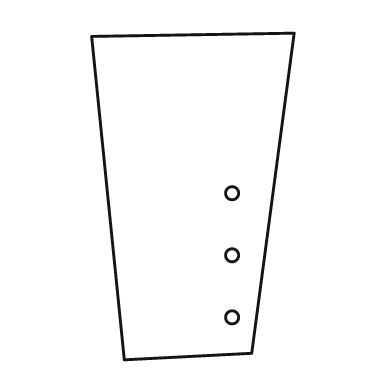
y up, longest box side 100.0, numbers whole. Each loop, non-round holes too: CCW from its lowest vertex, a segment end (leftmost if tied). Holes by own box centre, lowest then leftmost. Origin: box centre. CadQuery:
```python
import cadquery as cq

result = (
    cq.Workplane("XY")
    .moveTo(-21.0, -50.0)
    .lineTo(18.0, -48.0)
    .lineTo(31.0, 50.0)
    .lineTo(-31.0, 49.0)
    .close()
    .moveTo(12.0, -37.0)
    .circle(2.0)
    .moveTo(12.0, -18.0)
    .circle(2.0)
    .moveTo(12.0, 1.0)
    .circle(2.0)
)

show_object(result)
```